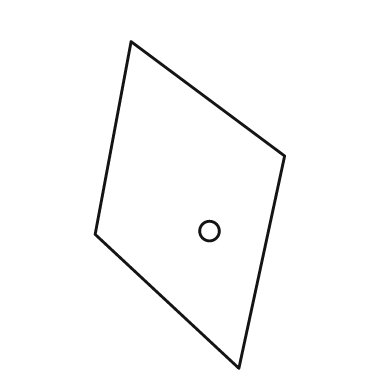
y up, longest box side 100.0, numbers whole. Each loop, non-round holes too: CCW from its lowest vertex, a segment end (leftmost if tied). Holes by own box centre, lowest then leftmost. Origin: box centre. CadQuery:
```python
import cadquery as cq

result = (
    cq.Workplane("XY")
    .moveTo(15.0, -50.0)
    .lineTo(29.0, 15.0)
    .lineTo(-18.0, 50.0)
    .lineTo(-29.0, -9.0)
    .close()
    .moveTo(6.0, -8.0)
    .circle(3.0)
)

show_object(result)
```